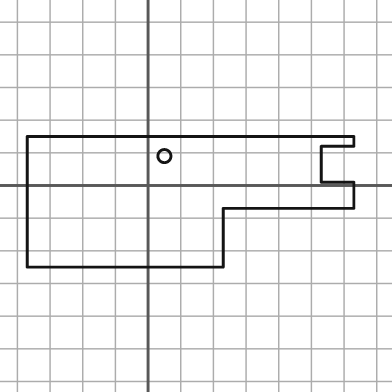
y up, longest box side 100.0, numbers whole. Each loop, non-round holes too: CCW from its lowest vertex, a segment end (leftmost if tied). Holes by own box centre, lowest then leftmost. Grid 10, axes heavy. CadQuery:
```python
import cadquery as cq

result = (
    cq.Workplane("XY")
    .moveTo(-37.0, -25.0)
    .lineTo(23.0, -25.0)
    .lineTo(23.0, -7.0)
    .lineTo(63.0, -7.0)
    .lineTo(63.0, 1.0)
    .lineTo(53.0, 1.0)
    .lineTo(53.0, 12.0)
    .lineTo(63.0, 12.0)
    .lineTo(63.0, 15.0)
    .lineTo(-37.0, 15.0)
    .close()
    .moveTo(5.0, 9.0)
    .circle(2.0)
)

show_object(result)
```